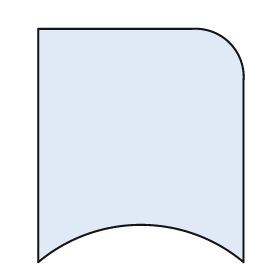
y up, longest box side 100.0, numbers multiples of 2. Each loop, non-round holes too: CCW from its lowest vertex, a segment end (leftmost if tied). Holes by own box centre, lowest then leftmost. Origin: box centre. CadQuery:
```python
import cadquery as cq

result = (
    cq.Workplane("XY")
    .moveTo(-44.0, -50.0)
    .threePointArc((0.0, -34.0), (44.0, -50.0))
    .lineTo(44.0, 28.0)
    .threePointArc((38.0, 44.0), (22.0, 50.0))
    .lineTo(-44.0, 50.0)
    .close()
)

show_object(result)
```